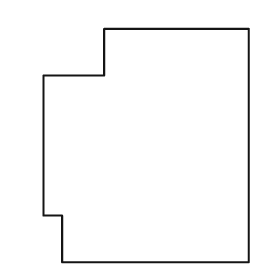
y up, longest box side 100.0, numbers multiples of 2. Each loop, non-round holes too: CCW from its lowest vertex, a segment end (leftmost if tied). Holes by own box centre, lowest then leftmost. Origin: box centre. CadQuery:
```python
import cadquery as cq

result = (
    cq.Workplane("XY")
    .moveTo(-36.0, -50.0)
    .lineTo(44.0, -50.0)
    .lineTo(44.0, 50.0)
    .lineTo(-18.0, 50.0)
    .lineTo(-18.0, 30.0)
    .lineTo(-44.0, 30.0)
    .lineTo(-44.0, -30.0)
    .lineTo(-36.0, -30.0)
    .close()
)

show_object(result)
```